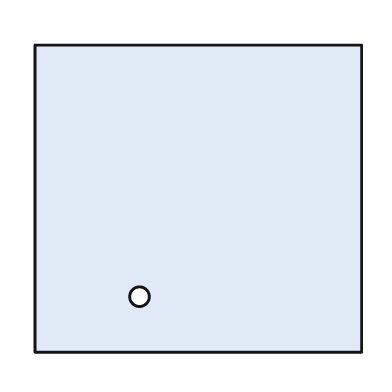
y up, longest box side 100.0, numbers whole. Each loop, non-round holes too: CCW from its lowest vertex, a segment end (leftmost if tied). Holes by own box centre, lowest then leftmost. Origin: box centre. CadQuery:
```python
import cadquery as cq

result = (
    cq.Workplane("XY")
    .moveTo(-50.0, -47.0)
    .lineTo(50.0, -47.0)
    .lineTo(50.0, 47.0)
    .lineTo(-50.0, 47.0)
    .close()
    .moveTo(-18.0, -30.0)
    .circle(3.0)
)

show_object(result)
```